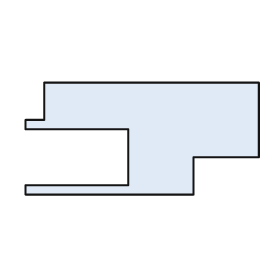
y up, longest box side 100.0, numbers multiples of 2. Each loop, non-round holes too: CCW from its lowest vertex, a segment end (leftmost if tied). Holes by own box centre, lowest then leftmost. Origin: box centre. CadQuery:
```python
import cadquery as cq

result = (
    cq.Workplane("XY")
    .moveTo(-50.0, -24.0)
    .lineTo(22.0, -24.0)
    .lineTo(22.0, -8.0)
    .lineTo(50.0, -8.0)
    .lineTo(50.0, 24.0)
    .lineTo(-42.0, 24.0)
    .lineTo(-42.0, 8.0)
    .lineTo(-50.0, 8.0)
    .lineTo(-50.0, 4.0)
    .lineTo(-6.0, 4.0)
    .lineTo(-6.0, -20.0)
    .lineTo(-50.0, -20.0)
    .close()
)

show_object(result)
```